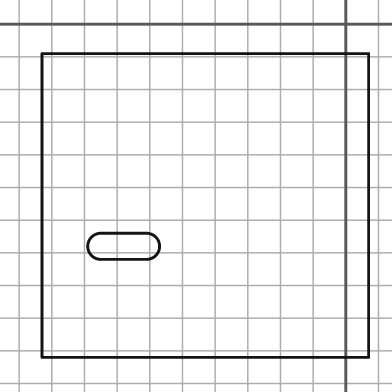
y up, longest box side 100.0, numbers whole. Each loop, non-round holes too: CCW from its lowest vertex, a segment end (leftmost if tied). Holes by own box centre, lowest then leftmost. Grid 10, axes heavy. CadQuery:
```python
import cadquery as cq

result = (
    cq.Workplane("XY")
    .moveTo(-93.0, -102.0)
    .lineTo(7.0, -102.0)
    .lineTo(7.0, -9.0)
    .lineTo(-93.0, -9.0)
    .close()
    .moveTo(-75.0, -72.0)
    .lineTo(-61.0, -72.0)
    .threePointArc((-57.0, -68.0), (-61.0, -64.0))
    .lineTo(-75.0, -64.0)
    .threePointArc((-79.0, -68.0), (-75.0, -72.0))
    .close()
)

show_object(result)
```